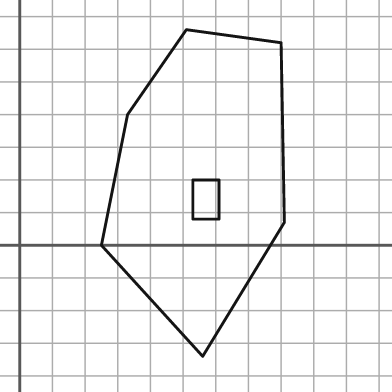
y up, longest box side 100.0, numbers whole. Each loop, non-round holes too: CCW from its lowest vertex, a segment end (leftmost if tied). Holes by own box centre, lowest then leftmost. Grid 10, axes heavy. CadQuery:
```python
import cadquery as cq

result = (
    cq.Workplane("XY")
    .moveTo(56.0, -34.0)
    .lineTo(81.0, 7.0)
    .lineTo(80.0, 62.0)
    .lineTo(51.0, 66.0)
    .lineTo(33.0, 40.0)
    .lineTo(25.0, 0.0)
    .close()
    .moveTo(53.0, 8.0)
    .lineTo(61.0, 8.0)
    .lineTo(61.0, 20.0)
    .lineTo(53.0, 20.0)
    .close()
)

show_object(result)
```